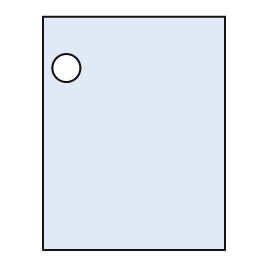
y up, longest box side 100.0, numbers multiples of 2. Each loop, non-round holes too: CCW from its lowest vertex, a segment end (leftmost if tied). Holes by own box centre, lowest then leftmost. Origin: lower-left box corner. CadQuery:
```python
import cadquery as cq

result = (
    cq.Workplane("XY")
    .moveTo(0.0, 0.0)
    .lineTo(78.0, 0.0)
    .lineTo(78.0, 100.0)
    .lineTo(0.0, 100.0)
    .close()
    .moveTo(10.0, 78.0)
    .circle(6.0)
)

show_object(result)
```